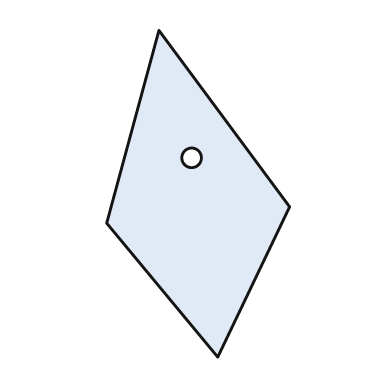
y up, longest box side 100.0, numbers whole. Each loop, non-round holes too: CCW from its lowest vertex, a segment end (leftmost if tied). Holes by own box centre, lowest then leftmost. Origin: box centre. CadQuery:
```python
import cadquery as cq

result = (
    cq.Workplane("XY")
    .moveTo(6.0, -50.0)
    .lineTo(28.0, -4.0)
    .lineTo(-12.0, 50.0)
    .lineTo(-28.0, -9.0)
    .close()
    .moveTo(-2.0, 11.0)
    .circle(3.0)
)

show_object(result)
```